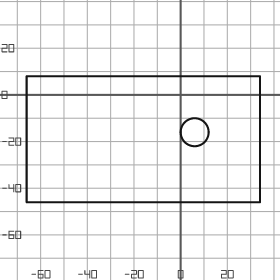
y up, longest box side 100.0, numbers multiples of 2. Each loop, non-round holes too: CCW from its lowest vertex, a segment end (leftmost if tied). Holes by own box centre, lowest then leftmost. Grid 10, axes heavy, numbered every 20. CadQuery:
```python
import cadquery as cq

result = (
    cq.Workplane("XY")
    .moveTo(-66.0, -46.0)
    .lineTo(34.0, -46.0)
    .lineTo(34.0, 8.0)
    .lineTo(-66.0, 8.0)
    .close()
    .moveTo(6.0, -16.0)
    .circle(6.0)
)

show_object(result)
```